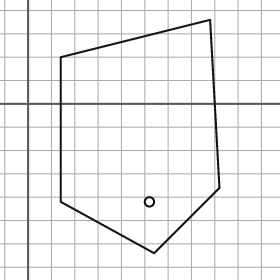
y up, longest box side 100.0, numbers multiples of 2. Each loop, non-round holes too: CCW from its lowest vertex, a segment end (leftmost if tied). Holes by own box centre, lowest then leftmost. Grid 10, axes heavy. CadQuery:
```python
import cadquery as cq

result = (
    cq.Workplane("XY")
    .moveTo(54.0, -64.0)
    .lineTo(82.0, -36.0)
    .lineTo(78.0, 36.0)
    .lineTo(14.0, 20.0)
    .lineTo(14.0, -42.0)
    .close()
    .moveTo(52.0, -42.0)
    .circle(2.0)
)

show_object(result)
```